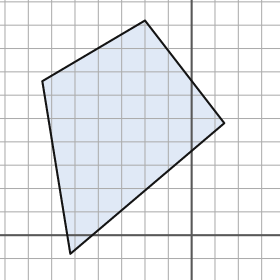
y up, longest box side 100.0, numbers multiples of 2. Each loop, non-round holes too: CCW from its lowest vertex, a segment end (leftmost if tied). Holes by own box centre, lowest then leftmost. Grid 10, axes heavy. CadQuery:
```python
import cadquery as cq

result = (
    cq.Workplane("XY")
    .moveTo(-52.0, -8.0)
    .lineTo(14.0, 48.0)
    .lineTo(-20.0, 92.0)
    .lineTo(-64.0, 66.0)
    .close()
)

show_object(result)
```